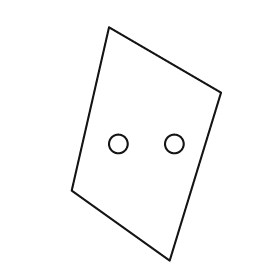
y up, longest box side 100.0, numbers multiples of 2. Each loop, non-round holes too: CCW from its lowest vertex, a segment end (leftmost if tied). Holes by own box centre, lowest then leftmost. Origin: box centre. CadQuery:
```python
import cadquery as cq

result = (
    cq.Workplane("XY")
    .moveTo(10.0, -50.0)
    .lineTo(32.0, 22.0)
    .lineTo(-16.0, 50.0)
    .lineTo(-32.0, -20.0)
    .close()
    .moveTo(-12.0, 0.0)
    .circle(4.0)
    .moveTo(12.0, 0.0)
    .circle(4.0)
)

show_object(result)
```